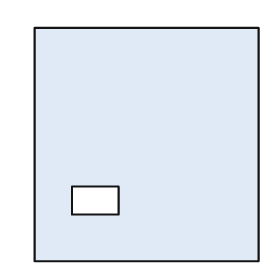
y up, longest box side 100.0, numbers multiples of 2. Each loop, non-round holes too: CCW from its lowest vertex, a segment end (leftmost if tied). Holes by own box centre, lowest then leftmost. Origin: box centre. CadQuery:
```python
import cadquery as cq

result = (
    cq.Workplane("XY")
    .moveTo(-48.0, -50.0)
    .lineTo(48.0, -50.0)
    .lineTo(48.0, 50.0)
    .lineTo(-48.0, 50.0)
    .close()
    .moveTo(-32.0, -30.0)
    .lineTo(-12.0, -30.0)
    .lineTo(-12.0, -18.0)
    .lineTo(-32.0, -18.0)
    .close()
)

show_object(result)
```